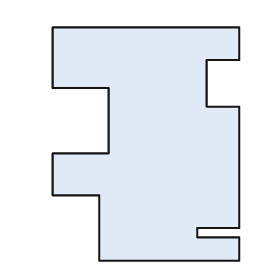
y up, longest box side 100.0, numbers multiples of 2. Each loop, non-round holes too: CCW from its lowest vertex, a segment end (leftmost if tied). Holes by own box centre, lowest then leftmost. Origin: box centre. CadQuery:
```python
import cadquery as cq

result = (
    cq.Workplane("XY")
    .moveTo(-20.0, -50.0)
    .lineTo(40.0, -50.0)
    .lineTo(40.0, -40.0)
    .lineTo(22.0, -40.0)
    .lineTo(22.0, -36.0)
    .lineTo(40.0, -36.0)
    .lineTo(40.0, 16.0)
    .lineTo(26.0, 16.0)
    .lineTo(26.0, 36.0)
    .lineTo(40.0, 36.0)
    .lineTo(40.0, 50.0)
    .lineTo(-40.0, 50.0)
    .lineTo(-40.0, 24.0)
    .lineTo(-16.0, 24.0)
    .lineTo(-16.0, -4.0)
    .lineTo(-40.0, -4.0)
    .lineTo(-40.0, -22.0)
    .lineTo(-20.0, -22.0)
    .close()
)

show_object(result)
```